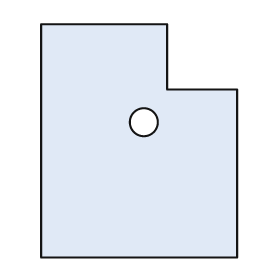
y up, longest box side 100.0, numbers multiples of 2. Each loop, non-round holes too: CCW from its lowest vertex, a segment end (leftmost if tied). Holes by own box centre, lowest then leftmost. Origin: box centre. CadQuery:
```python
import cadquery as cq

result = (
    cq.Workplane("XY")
    .moveTo(-42.0, -50.0)
    .lineTo(42.0, -50.0)
    .lineTo(42.0, 22.0)
    .lineTo(12.0, 22.0)
    .lineTo(12.0, 50.0)
    .lineTo(-42.0, 50.0)
    .close()
    .moveTo(2.0, 8.0)
    .circle(6.0)
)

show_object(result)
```